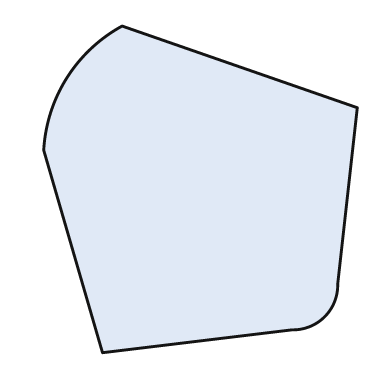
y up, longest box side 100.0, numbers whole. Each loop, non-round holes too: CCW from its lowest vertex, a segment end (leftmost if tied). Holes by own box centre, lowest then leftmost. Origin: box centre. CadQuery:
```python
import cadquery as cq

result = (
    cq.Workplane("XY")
    .moveTo(-30.0, -50.0)
    .lineTo(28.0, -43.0)
    .threePointArc((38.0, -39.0), (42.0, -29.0))
    .lineTo(48.0, 25.0)
    .lineTo(-24.0, 50.0)
    .threePointArc((-41.0, 34.0), (-48.0, 12.0))
    .close()
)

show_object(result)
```